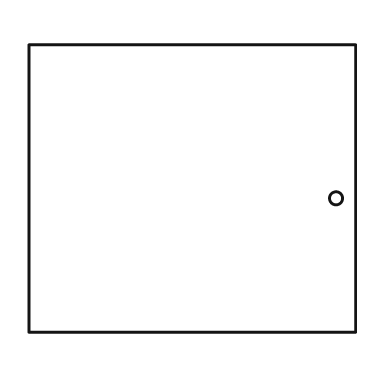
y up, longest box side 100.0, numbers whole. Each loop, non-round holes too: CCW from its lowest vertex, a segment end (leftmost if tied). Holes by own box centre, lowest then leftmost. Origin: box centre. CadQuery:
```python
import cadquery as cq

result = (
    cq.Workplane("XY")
    .moveTo(-50.0, -44.0)
    .lineTo(50.0, -44.0)
    .lineTo(50.0, 44.0)
    .lineTo(-50.0, 44.0)
    .close()
    .moveTo(44.0, -3.0)
    .circle(2.0)
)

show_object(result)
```